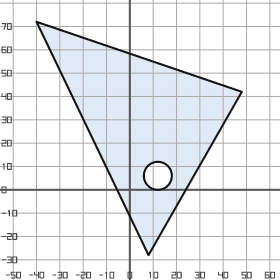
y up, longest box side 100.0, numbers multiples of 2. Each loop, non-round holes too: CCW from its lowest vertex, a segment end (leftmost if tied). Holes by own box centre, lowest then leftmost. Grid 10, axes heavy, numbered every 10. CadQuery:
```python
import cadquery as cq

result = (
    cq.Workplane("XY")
    .moveTo(8.0, -28.0)
    .lineTo(48.0, 42.0)
    .lineTo(-40.0, 72.0)
    .close()
    .moveTo(12.0, 6.0)
    .circle(6.0)
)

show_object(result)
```